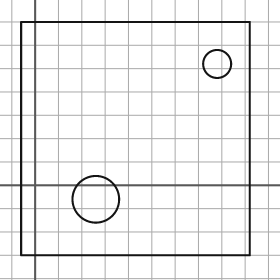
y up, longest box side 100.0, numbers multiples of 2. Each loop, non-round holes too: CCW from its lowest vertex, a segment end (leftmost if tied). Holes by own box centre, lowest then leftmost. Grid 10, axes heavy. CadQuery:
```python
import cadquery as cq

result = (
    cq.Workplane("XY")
    .moveTo(-6.0, -30.0)
    .lineTo(92.0, -30.0)
    .lineTo(92.0, 70.0)
    .lineTo(-6.0, 70.0)
    .close()
    .moveTo(26.0, -6.0)
    .circle(10.0)
    .moveTo(78.0, 52.0)
    .circle(6.0)
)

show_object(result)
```